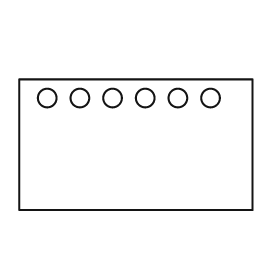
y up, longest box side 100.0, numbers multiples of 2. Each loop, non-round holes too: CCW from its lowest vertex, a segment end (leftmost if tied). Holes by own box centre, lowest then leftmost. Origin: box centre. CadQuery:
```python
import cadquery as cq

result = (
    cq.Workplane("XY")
    .moveTo(-50.0, -28.0)
    .lineTo(50.0, -28.0)
    .lineTo(50.0, 28.0)
    .lineTo(-50.0, 28.0)
    .close()
    .moveTo(-38.0, 20.0)
    .circle(4.0)
    .moveTo(-24.0, 20.0)
    .circle(4.0)
    .moveTo(-10.0, 20.0)
    .circle(4.0)
    .moveTo(4.0, 20.0)
    .circle(4.0)
    .moveTo(18.0, 20.0)
    .circle(4.0)
    .moveTo(32.0, 20.0)
    .circle(4.0)
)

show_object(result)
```